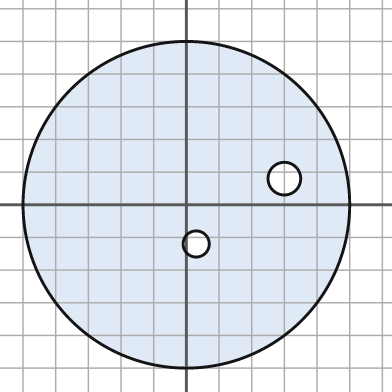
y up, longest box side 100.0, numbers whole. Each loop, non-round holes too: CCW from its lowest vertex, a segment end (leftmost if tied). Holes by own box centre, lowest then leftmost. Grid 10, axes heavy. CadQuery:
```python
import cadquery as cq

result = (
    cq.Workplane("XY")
    .moveTo(0.0, 0.0)
    .circle(50.0)
    .moveTo(3.0, -12.0)
    .circle(4.0)
    .moveTo(30.0, 8.0)
    .circle(5.0)
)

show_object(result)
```